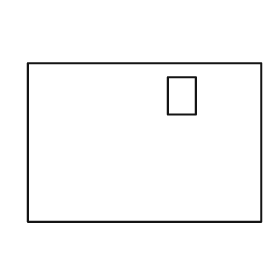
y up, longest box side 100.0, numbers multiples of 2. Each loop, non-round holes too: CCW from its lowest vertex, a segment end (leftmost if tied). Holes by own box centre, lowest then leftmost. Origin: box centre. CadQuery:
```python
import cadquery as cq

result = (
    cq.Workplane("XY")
    .moveTo(-50.0, -34.0)
    .lineTo(50.0, -34.0)
    .lineTo(50.0, 34.0)
    .lineTo(-50.0, 34.0)
    .close()
    .moveTo(10.0, 12.0)
    .lineTo(22.0, 12.0)
    .lineTo(22.0, 28.0)
    .lineTo(10.0, 28.0)
    .close()
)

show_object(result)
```